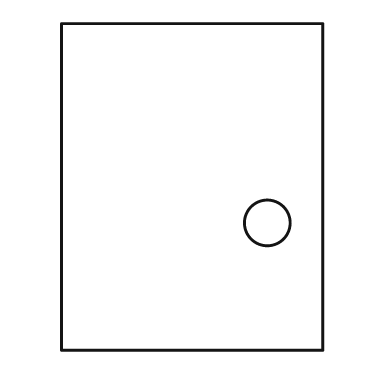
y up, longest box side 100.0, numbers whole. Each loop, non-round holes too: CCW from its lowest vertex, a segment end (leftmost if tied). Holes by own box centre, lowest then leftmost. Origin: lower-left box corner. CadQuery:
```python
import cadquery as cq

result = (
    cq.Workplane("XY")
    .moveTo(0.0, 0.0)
    .lineTo(80.0, 0.0)
    .lineTo(80.0, 100.0)
    .lineTo(0.0, 100.0)
    .close()
    .moveTo(63.0, 39.0)
    .circle(7.0)
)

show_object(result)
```